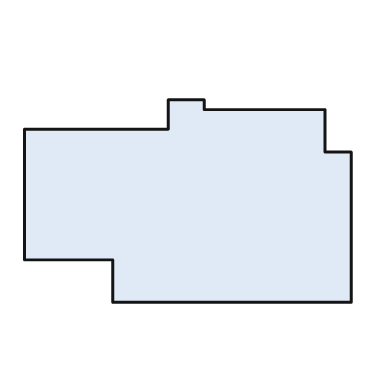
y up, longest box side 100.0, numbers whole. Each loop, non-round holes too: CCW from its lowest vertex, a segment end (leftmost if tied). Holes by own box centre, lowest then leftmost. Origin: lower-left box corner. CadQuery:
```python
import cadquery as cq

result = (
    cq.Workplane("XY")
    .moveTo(27.0, 0.0)
    .lineTo(100.0, 0.0)
    .lineTo(100.0, 46.0)
    .lineTo(92.0, 46.0)
    .lineTo(92.0, 59.0)
    .lineTo(55.0, 59.0)
    .lineTo(55.0, 62.0)
    .lineTo(44.0, 62.0)
    .lineTo(44.0, 53.0)
    .lineTo(0.0, 53.0)
    .lineTo(0.0, 13.0)
    .lineTo(27.0, 13.0)
    .close()
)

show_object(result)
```